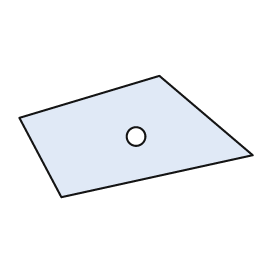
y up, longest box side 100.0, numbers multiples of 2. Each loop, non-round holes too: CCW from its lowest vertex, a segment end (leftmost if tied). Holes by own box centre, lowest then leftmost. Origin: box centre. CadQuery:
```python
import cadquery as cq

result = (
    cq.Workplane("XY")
    .moveTo(-32.0, -26.0)
    .lineTo(50.0, -8.0)
    .lineTo(10.0, 26.0)
    .lineTo(-50.0, 8.0)
    .close()
    .moveTo(0.0, 0.0)
    .circle(4.0)
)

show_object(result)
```